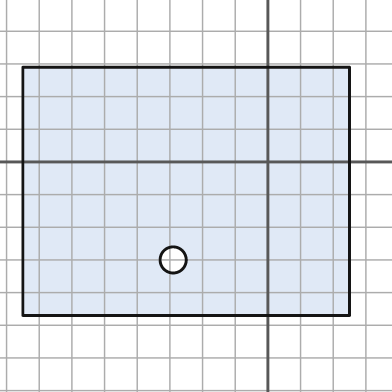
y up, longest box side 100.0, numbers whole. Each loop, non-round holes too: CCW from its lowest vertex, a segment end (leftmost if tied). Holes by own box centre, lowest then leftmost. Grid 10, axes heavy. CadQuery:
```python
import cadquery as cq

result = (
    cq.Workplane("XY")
    .moveTo(-75.0, -47.0)
    .lineTo(25.0, -47.0)
    .lineTo(25.0, 29.0)
    .lineTo(-75.0, 29.0)
    .close()
    .moveTo(-29.0, -30.0)
    .circle(4.0)
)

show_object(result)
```